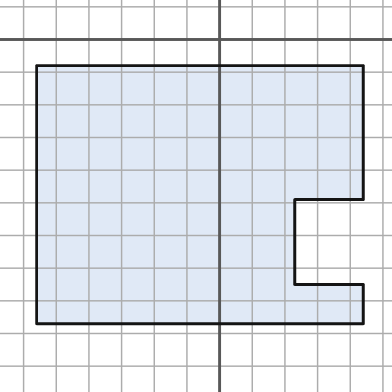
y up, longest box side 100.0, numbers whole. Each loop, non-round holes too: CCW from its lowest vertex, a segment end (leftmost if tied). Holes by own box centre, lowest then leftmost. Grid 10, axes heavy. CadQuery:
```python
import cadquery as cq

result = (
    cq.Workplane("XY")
    .moveTo(-56.0, -87.0)
    .lineTo(44.0, -87.0)
    .lineTo(44.0, -75.0)
    .lineTo(23.0, -75.0)
    .lineTo(23.0, -49.0)
    .lineTo(44.0, -49.0)
    .lineTo(44.0, -8.0)
    .lineTo(-56.0, -8.0)
    .close()
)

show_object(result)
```